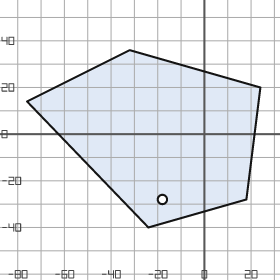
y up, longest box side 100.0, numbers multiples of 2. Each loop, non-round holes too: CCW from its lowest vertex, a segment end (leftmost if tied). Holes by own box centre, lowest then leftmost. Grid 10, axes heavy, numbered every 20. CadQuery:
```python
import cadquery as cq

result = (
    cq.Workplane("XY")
    .moveTo(-24.0, -40.0)
    .lineTo(18.0, -28.0)
    .lineTo(24.0, 20.0)
    .lineTo(-32.0, 36.0)
    .lineTo(-76.0, 14.0)
    .close()
    .moveTo(-18.0, -28.0)
    .circle(2.0)
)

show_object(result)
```